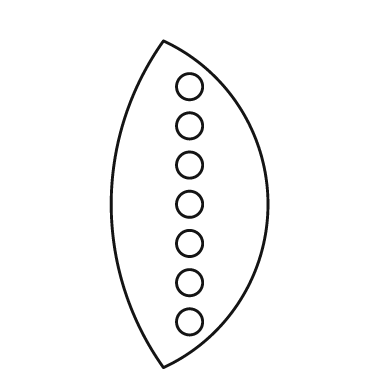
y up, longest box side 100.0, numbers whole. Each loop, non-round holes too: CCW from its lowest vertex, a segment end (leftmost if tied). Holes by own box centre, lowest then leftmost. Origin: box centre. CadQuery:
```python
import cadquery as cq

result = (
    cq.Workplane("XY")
    .moveTo(-8.0, -50.0)
    .threePointArc((24.0, 0.0), (-8.0, 50.0))
    .threePointArc((-24.0, 0.0), (-8.0, -50.0))
    .close()
    .moveTo(0.0, -36.0)
    .circle(4.0)
    .moveTo(0.0, -24.0)
    .circle(4.0)
    .moveTo(0.0, -12.0)
    .circle(4.0)
    .moveTo(0.0, 0.0)
    .circle(4.0)
    .moveTo(0.0, 12.0)
    .circle(4.0)
    .moveTo(0.0, 24.0)
    .circle(4.0)
    .moveTo(0.0, 36.0)
    .circle(4.0)
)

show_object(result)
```